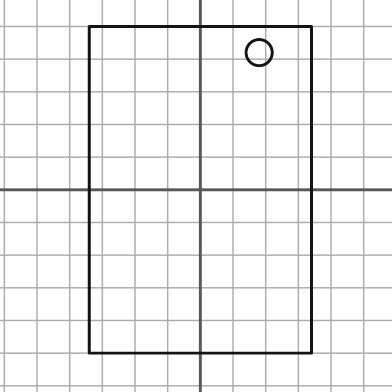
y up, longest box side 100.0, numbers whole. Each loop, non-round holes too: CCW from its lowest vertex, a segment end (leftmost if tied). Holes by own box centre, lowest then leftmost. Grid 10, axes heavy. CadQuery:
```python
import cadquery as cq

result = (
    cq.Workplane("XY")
    .moveTo(-34.0, -50.0)
    .lineTo(34.0, -50.0)
    .lineTo(34.0, 50.0)
    .lineTo(-34.0, 50.0)
    .close()
    .moveTo(18.0, 42.0)
    .circle(4.0)
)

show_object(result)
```